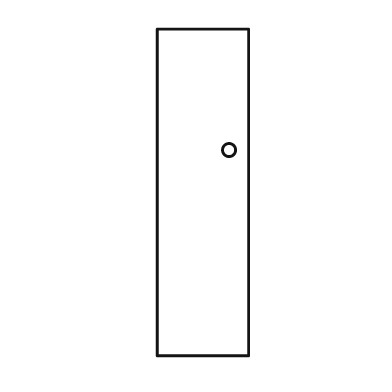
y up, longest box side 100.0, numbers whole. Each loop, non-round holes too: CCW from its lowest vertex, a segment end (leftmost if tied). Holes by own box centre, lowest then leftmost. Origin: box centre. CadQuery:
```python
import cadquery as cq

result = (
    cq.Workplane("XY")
    .moveTo(-14.0, -50.0)
    .lineTo(14.0, -50.0)
    .lineTo(14.0, 50.0)
    .lineTo(-14.0, 50.0)
    .close()
    .moveTo(8.0, 13.0)
    .circle(2.0)
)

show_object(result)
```